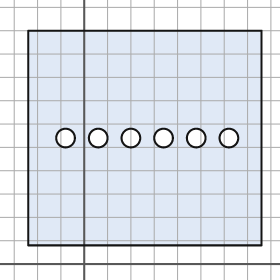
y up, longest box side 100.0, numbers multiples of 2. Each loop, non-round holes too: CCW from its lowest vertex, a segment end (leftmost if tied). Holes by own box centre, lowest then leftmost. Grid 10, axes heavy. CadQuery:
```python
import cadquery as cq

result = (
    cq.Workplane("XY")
    .moveTo(-24.0, 8.0)
    .lineTo(76.0, 8.0)
    .lineTo(76.0, 100.0)
    .lineTo(-24.0, 100.0)
    .close()
    .moveTo(-8.0, 54.0)
    .circle(4.0)
    .moveTo(6.0, 54.0)
    .circle(4.0)
    .moveTo(20.0, 54.0)
    .circle(4.0)
    .moveTo(34.0, 54.0)
    .circle(4.0)
    .moveTo(48.0, 54.0)
    .circle(4.0)
    .moveTo(62.0, 54.0)
    .circle(4.0)
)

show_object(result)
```